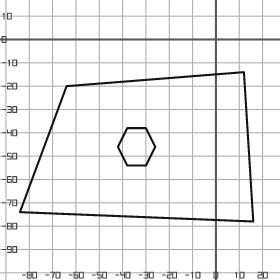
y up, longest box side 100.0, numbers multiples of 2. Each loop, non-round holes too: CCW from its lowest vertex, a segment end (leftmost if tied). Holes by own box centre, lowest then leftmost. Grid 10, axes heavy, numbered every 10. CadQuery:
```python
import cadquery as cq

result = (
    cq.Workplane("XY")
    .moveTo(16.0, -78.0)
    .lineTo(12.0, -14.0)
    .lineTo(-64.0, -20.0)
    .lineTo(-84.0, -74.0)
    .close()
    .moveTo(-38.0, -54.0)
    .lineTo(-30.0, -54.0)
    .lineTo(-26.0, -46.0)
    .lineTo(-30.0, -38.0)
    .lineTo(-38.0, -38.0)
    .lineTo(-42.0, -46.0)
    .close()
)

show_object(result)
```